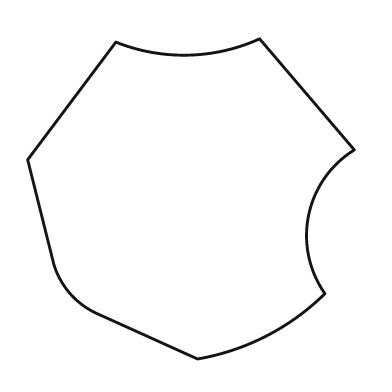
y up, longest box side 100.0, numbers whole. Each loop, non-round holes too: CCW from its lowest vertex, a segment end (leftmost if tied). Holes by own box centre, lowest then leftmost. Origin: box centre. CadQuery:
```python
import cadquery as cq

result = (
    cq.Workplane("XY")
    .moveTo(2.0, -49.0)
    .threePointArc((23.0, -42.0), (41.0, -29.0))
    .threePointArc((36.0, -5.0), (50.0, 15.0))
    .lineTo(21.0, 49.0)
    .threePointArc((-1.0, 44.0), (-23.0, 48.0))
    .lineTo(-50.0, 12.0)
    .lineTo(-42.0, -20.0)
    .threePointArc((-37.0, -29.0), (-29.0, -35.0))
    .close()
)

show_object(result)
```